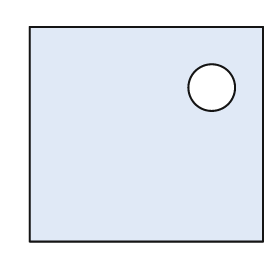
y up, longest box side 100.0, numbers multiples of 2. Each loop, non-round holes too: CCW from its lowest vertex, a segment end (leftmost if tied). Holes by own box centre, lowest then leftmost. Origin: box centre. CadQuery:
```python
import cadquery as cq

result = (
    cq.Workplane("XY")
    .moveTo(-50.0, -46.0)
    .lineTo(50.0, -46.0)
    .lineTo(50.0, 46.0)
    .lineTo(-50.0, 46.0)
    .close()
    .moveTo(28.0, 20.0)
    .circle(10.0)
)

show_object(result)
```